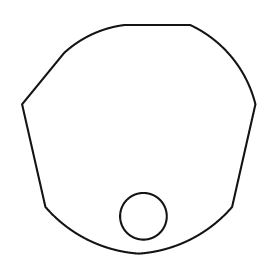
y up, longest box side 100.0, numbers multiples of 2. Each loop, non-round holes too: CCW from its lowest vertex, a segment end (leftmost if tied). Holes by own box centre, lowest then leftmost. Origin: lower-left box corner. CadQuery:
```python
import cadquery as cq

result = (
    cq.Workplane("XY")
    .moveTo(50.0, 0.0)
    .threePointArc((72.0, 6.0), (90.0, 20.0))
    .lineTo(100.0, 64.0)
    .threePointArc((90.0, 84.0), (72.0, 98.0))
    .lineTo(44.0, 98.0)
    .threePointArc((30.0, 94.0), (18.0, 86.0))
    .lineTo(0.0, 64.0)
    .lineTo(10.0, 20.0)
    .threePointArc((28.0, 6.0), (50.0, 0.0))
    .close()
    .moveTo(52.0, 16.0)
    .circle(10.0)
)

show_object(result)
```